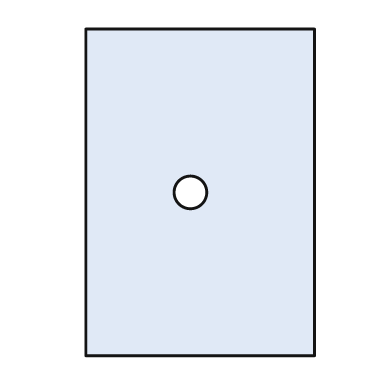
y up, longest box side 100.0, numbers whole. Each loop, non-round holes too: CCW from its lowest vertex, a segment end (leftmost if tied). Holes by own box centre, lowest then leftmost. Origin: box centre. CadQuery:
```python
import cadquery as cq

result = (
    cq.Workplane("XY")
    .moveTo(-35.0, -50.0)
    .lineTo(35.0, -50.0)
    .lineTo(35.0, 50.0)
    .lineTo(-35.0, 50.0)
    .close()
    .moveTo(-3.0, 0.0)
    .circle(5.0)
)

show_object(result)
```